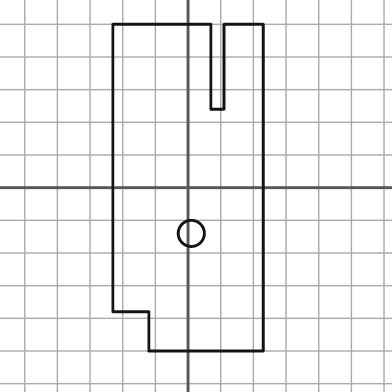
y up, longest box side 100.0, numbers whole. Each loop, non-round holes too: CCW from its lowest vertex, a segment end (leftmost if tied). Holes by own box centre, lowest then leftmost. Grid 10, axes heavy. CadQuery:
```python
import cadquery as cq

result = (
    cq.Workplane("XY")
    .moveTo(-12.0, -50.0)
    .lineTo(23.0, -50.0)
    .lineTo(23.0, 50.0)
    .lineTo(11.0, 50.0)
    .lineTo(11.0, 24.0)
    .lineTo(7.0, 24.0)
    .lineTo(7.0, 50.0)
    .lineTo(-23.0, 50.0)
    .lineTo(-23.0, -38.0)
    .lineTo(-12.0, -38.0)
    .close()
    .moveTo(1.0, -14.0)
    .circle(4.0)
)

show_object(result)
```